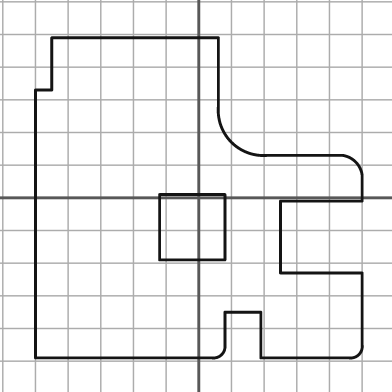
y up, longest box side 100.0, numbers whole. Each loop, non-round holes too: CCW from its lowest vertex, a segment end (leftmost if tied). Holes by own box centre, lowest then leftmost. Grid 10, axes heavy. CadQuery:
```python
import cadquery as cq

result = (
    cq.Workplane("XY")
    .moveTo(-50.0, -49.0)
    .lineTo(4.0, -49.0)
    .threePointArc((7.0, -48.0), (8.0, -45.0))
    .lineTo(8.0, -35.0)
    .lineTo(19.0, -35.0)
    .lineTo(19.0, -49.0)
    .lineTo(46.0, -49.0)
    .threePointArc((49.0, -48.0), (50.0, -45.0))
    .lineTo(50.0, -23.0)
    .lineTo(25.0, -23.0)
    .lineTo(25.0, -1.0)
    .lineTo(50.0, -1.0)
    .lineTo(50.0, 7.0)
    .threePointArc((48.0, 11.0), (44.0, 13.0))
    .lineTo(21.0, 13.0)
    .threePointArc((10.0, 17.0), (6.0, 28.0))
    .lineTo(6.0, 49.0)
    .lineTo(-45.0, 49.0)
    .lineTo(-45.0, 33.0)
    .lineTo(-50.0, 33.0)
    .close()
    .moveTo(-12.0, -19.0)
    .lineTo(8.0, -19.0)
    .lineTo(8.0, 1.0)
    .lineTo(-12.0, 1.0)
    .close()
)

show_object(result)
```